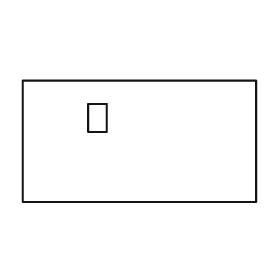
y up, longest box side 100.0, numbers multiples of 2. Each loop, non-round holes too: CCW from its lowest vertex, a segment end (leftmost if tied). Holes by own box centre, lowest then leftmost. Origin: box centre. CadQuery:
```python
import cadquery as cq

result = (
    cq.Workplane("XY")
    .moveTo(-50.0, -26.0)
    .lineTo(50.0, -26.0)
    .lineTo(50.0, 26.0)
    .lineTo(-50.0, 26.0)
    .close()
    .moveTo(-22.0, 4.0)
    .lineTo(-14.0, 4.0)
    .lineTo(-14.0, 16.0)
    .lineTo(-22.0, 16.0)
    .close()
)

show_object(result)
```